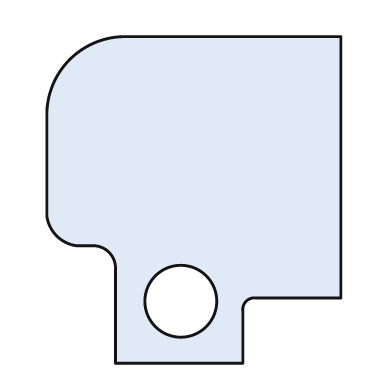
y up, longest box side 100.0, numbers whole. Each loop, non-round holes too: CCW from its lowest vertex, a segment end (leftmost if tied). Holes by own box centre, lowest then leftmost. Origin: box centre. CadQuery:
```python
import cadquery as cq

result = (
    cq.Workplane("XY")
    .moveTo(-24.0, -50.0)
    .lineTo(15.0, -50.0)
    .lineTo(15.0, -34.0)
    .threePointArc((16.0, -31.0), (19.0, -30.0))
    .lineTo(45.0, -30.0)
    .lineTo(45.0, 50.0)
    .lineTo(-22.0, 50.0)
    .threePointArc((-38.0, 43.0), (-45.0, 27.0))
    .lineTo(-45.0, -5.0)
    .threePointArc((-42.0, -11.0), (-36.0, -14.0))
    .lineTo(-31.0, -14.0)
    .threePointArc((-26.0, -16.0), (-24.0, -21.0))
    .close()
    .moveTo(-4.0, -31.0)
    .circle(11.0)
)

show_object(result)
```